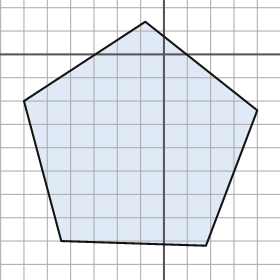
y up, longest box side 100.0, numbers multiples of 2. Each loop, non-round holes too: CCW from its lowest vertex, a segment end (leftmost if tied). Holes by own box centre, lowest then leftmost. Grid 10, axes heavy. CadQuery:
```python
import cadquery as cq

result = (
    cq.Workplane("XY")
    .moveTo(18.0, -82.0)
    .lineTo(40.0, -24.0)
    .lineTo(-8.0, 14.0)
    .lineTo(-60.0, -20.0)
    .lineTo(-44.0, -80.0)
    .close()
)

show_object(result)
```